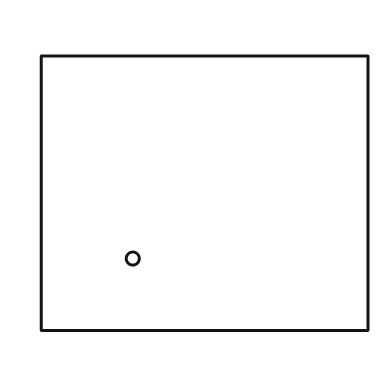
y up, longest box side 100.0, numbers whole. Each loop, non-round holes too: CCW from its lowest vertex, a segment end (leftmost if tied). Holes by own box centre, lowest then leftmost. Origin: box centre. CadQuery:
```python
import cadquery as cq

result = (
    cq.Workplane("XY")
    .moveTo(-50.0, -42.0)
    .lineTo(50.0, -42.0)
    .lineTo(50.0, 42.0)
    .lineTo(-50.0, 42.0)
    .close()
    .moveTo(-22.0, -20.0)
    .circle(2.0)
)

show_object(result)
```